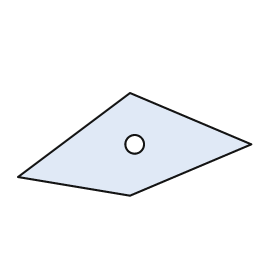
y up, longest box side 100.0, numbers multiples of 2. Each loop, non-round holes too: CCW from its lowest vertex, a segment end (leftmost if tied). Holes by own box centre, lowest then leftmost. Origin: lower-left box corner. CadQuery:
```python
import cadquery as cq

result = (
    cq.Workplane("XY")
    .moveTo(48.0, 0.0)
    .lineTo(100.0, 22.0)
    .lineTo(48.0, 44.0)
    .lineTo(0.0, 8.0)
    .close()
    .moveTo(50.0, 22.0)
    .circle(4.0)
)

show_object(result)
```